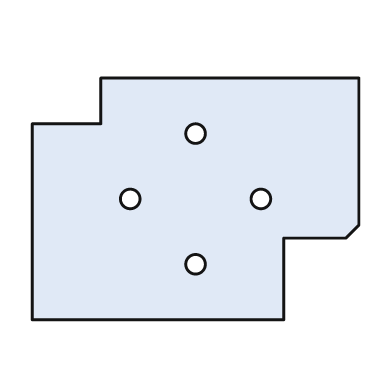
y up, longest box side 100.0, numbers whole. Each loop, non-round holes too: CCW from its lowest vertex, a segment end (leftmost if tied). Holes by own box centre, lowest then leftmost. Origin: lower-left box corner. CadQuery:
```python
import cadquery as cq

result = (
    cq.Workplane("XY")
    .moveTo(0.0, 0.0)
    .lineTo(77.0, 0.0)
    .lineTo(77.0, 25.0)
    .lineTo(96.0, 25.0)
    .lineTo(100.0, 29.0)
    .lineTo(100.0, 74.0)
    .lineTo(21.0, 74.0)
    .lineTo(21.0, 60.0)
    .lineTo(0.0, 60.0)
    .close()
    .moveTo(50.0, 17.0)
    .circle(3.0)
    .moveTo(30.0, 37.0)
    .circle(3.0)
    .moveTo(70.0, 37.0)
    .circle(3.0)
    .moveTo(50.0, 57.0)
    .circle(3.0)
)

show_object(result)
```